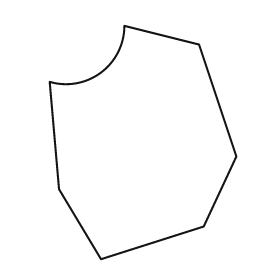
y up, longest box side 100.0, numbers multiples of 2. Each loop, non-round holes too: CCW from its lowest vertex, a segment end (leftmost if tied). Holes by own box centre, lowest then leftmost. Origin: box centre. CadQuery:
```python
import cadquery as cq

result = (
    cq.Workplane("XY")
    .moveTo(-18.0, -50.0)
    .lineTo(26.0, -36.0)
    .lineTo(40.0, -6.0)
    .lineTo(24.0, 42.0)
    .lineTo(-8.0, 50.0)
    .threePointArc((-18.0, 30.0), (-40.0, 26.0))
    .lineTo(-36.0, -20.0)
    .close()
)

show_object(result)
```